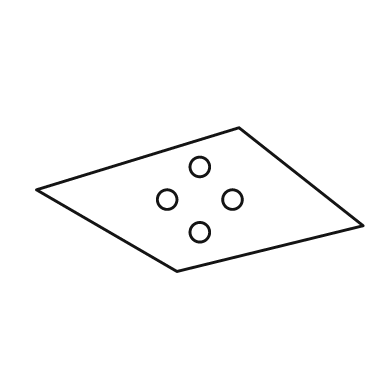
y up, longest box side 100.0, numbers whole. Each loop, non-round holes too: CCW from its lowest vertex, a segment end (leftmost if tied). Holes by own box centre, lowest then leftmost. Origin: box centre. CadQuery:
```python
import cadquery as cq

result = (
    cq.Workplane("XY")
    .moveTo(-7.0, -22.0)
    .lineTo(50.0, -8.0)
    .lineTo(12.0, 22.0)
    .lineTo(-50.0, 3.0)
    .close()
    .moveTo(0.0, -10.0)
    .circle(3.0)
    .moveTo(-10.0, 0.0)
    .circle(3.0)
    .moveTo(10.0, 0.0)
    .circle(3.0)
    .moveTo(0.0, 10.0)
    .circle(3.0)
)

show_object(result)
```